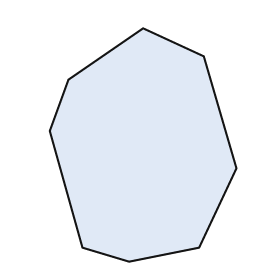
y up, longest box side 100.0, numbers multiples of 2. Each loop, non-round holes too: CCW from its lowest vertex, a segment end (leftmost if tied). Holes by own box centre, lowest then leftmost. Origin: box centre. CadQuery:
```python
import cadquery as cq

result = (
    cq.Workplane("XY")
    .moveTo(-6.0, -50.0)
    .lineTo(24.0, -44.0)
    .lineTo(40.0, -10.0)
    .lineTo(26.0, 38.0)
    .lineTo(0.0, 50.0)
    .lineTo(-32.0, 28.0)
    .lineTo(-40.0, 6.0)
    .lineTo(-26.0, -44.0)
    .close()
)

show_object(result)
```